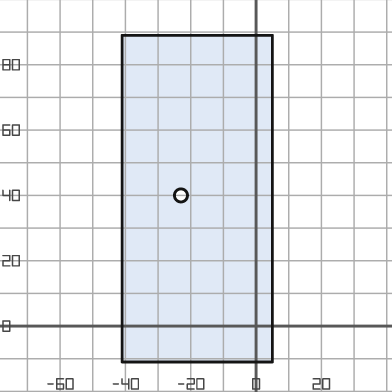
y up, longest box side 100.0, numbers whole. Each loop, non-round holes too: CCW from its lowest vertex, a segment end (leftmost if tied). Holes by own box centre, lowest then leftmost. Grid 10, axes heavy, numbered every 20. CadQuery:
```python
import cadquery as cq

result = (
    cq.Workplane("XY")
    .moveTo(-41.0, -11.0)
    .lineTo(5.0, -11.0)
    .lineTo(5.0, 89.0)
    .lineTo(-41.0, 89.0)
    .close()
    .moveTo(-23.0, 40.0)
    .circle(2.0)
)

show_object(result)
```